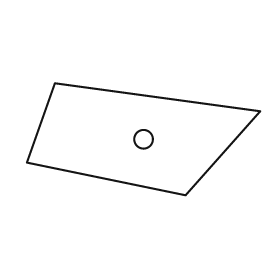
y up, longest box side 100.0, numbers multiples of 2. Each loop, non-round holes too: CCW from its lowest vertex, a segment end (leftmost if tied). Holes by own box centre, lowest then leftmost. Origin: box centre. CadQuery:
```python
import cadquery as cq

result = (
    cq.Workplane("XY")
    .moveTo(18.0, -24.0)
    .lineTo(50.0, 12.0)
    .lineTo(-38.0, 24.0)
    .lineTo(-50.0, -10.0)
    .close()
    .moveTo(0.0, 0.0)
    .circle(4.0)
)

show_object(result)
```